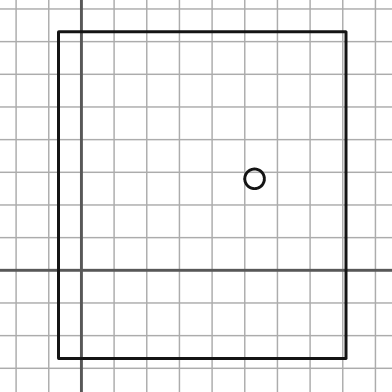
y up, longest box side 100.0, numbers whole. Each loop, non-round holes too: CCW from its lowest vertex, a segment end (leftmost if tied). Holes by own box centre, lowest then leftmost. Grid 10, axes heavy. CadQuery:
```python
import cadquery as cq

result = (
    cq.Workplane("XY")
    .moveTo(-7.0, -27.0)
    .lineTo(81.0, -27.0)
    .lineTo(81.0, 73.0)
    .lineTo(-7.0, 73.0)
    .close()
    .moveTo(53.0, 28.0)
    .circle(3.0)
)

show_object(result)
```